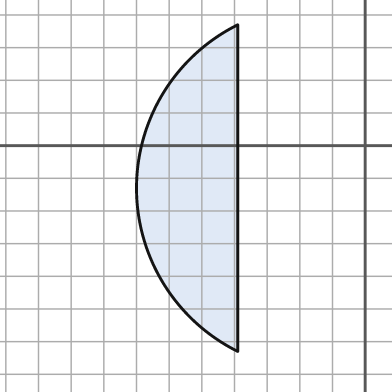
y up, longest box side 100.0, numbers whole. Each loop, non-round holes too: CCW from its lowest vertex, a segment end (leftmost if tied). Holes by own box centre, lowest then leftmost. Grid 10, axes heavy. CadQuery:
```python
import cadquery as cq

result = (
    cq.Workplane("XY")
    .moveTo(-39.0, -63.0)
    .lineTo(-39.0, 37.0)
    .threePointArc((-70.0, -13.0), (-39.0, -63.0))
    .close()
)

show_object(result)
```